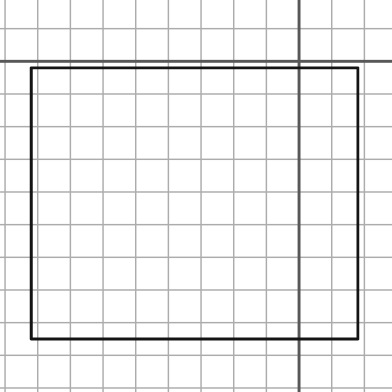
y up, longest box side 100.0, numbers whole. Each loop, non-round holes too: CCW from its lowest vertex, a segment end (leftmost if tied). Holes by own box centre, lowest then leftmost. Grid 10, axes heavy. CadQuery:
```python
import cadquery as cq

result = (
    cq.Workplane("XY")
    .moveTo(-82.0, -85.0)
    .lineTo(18.0, -85.0)
    .lineTo(18.0, -2.0)
    .lineTo(-82.0, -2.0)
    .close()
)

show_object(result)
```